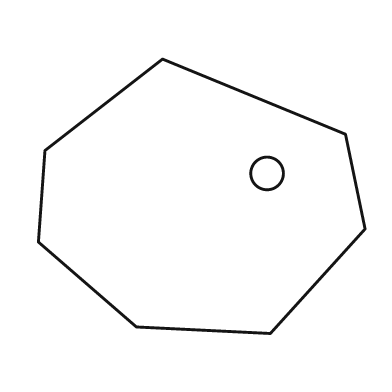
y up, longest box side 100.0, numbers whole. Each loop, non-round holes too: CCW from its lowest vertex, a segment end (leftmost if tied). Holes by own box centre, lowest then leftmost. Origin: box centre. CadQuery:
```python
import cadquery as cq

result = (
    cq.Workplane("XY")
    .moveTo(21.0, -42.0)
    .lineTo(50.0, -10.0)
    .lineTo(44.0, 19.0)
    .lineTo(-12.0, 42.0)
    .lineTo(-48.0, 14.0)
    .lineTo(-50.0, -14.0)
    .lineTo(-20.0, -40.0)
    .close()
    .moveTo(20.0, 7.0)
    .circle(5.0)
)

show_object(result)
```